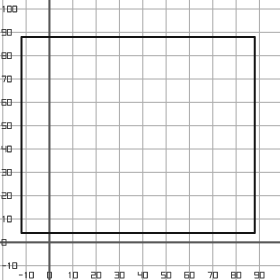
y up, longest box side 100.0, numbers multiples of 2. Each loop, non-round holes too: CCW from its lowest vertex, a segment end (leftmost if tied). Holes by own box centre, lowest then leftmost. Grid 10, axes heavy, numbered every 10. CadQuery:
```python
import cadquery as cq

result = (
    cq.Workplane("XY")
    .moveTo(-12.0, 4.0)
    .lineTo(88.0, 4.0)
    .lineTo(88.0, 88.0)
    .lineTo(-12.0, 88.0)
    .close()
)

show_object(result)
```